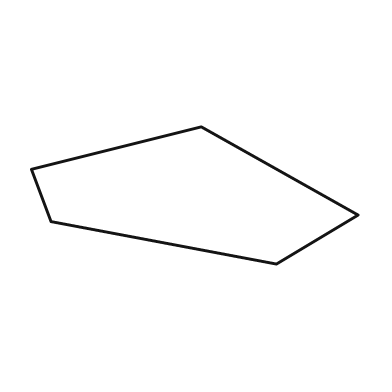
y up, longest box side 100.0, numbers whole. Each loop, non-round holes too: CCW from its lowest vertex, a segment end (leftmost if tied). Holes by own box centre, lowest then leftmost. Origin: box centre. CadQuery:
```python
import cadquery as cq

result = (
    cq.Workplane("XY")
    .moveTo(25.0, -21.0)
    .lineTo(50.0, -6.0)
    .lineTo(2.0, 21.0)
    .lineTo(-50.0, 8.0)
    .lineTo(-44.0, -8.0)
    .close()
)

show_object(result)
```